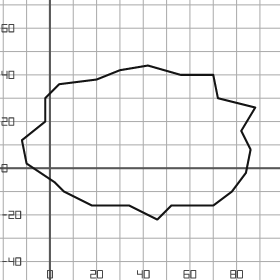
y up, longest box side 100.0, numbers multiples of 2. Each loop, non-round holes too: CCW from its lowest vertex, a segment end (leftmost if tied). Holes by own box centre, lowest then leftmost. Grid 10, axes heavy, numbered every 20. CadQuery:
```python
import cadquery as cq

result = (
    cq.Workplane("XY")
    .moveTo(46.0, -22.0)
    .lineTo(52.0, -16.0)
    .lineTo(70.0, -16.0)
    .lineTo(78.0, -10.0)
    .lineTo(84.0, -2.0)
    .lineTo(86.0, 8.0)
    .lineTo(82.0, 16.0)
    .lineTo(88.0, 26.0)
    .lineTo(72.0, 30.0)
    .lineTo(70.0, 40.0)
    .lineTo(56.0, 40.0)
    .lineTo(42.0, 44.0)
    .lineTo(30.0, 42.0)
    .lineTo(20.0, 38.0)
    .lineTo(4.0, 36.0)
    .lineTo(-2.0, 30.0)
    .lineTo(-2.0, 20.0)
    .lineTo(-12.0, 12.0)
    .lineTo(-10.0, 2.0)
    .lineTo(2.0, -6.0)
    .lineTo(6.0, -10.0)
    .lineTo(18.0, -16.0)
    .lineTo(34.0, -16.0)
    .close()
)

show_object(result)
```